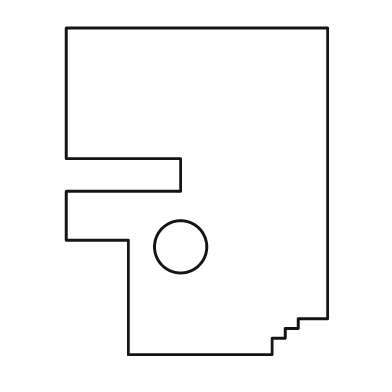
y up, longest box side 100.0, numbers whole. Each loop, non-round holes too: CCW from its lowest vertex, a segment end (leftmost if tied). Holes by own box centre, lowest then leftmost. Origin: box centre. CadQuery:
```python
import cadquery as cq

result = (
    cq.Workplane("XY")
    .moveTo(-21.0, -50.0)
    .lineTo(23.0, -50.0)
    .lineTo(23.0, -45.0)
    .lineTo(27.0, -45.0)
    .lineTo(27.0, -42.0)
    .lineTo(31.0, -42.0)
    .lineTo(31.0, -39.0)
    .lineTo(40.0, -39.0)
    .lineTo(40.0, 50.0)
    .lineTo(-40.0, 50.0)
    .lineTo(-40.0, 10.0)
    .lineTo(-5.0, 10.0)
    .lineTo(-5.0, 0.0)
    .lineTo(-40.0, 0.0)
    .lineTo(-40.0, -15.0)
    .lineTo(-21.0, -15.0)
    .close()
    .moveTo(-5.0, -17.0)
    .circle(8.0)
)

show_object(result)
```